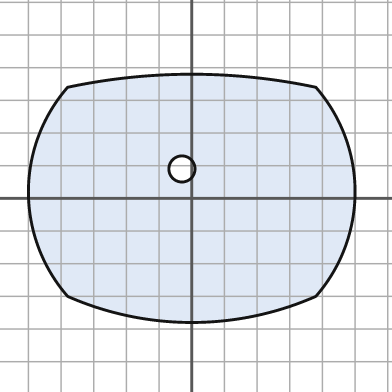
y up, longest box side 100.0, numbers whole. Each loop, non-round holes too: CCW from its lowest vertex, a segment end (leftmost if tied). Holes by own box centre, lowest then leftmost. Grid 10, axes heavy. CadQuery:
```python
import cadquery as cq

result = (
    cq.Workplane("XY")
    .moveTo(-38.0, -30.0)
    .threePointArc((0.0, -38.0), (38.0, -30.0))
    .threePointArc((50.0, 2.0), (38.0, 34.0))
    .threePointArc((0.0, 38.0), (-38.0, 34.0))
    .threePointArc((-50.0, 2.0), (-38.0, -30.0))
    .close()
    .moveTo(-3.0, 9.0)
    .circle(4.0)
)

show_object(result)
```